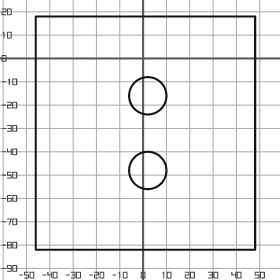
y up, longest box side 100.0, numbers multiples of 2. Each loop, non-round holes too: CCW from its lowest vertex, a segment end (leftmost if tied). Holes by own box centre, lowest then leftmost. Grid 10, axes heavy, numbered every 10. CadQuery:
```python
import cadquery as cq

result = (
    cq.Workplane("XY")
    .moveTo(-46.0, -82.0)
    .lineTo(48.0, -82.0)
    .lineTo(48.0, 18.0)
    .lineTo(-46.0, 18.0)
    .close()
    .moveTo(2.0, -48.0)
    .circle(8.0)
    .moveTo(2.0, -16.0)
    .circle(8.0)
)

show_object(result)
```